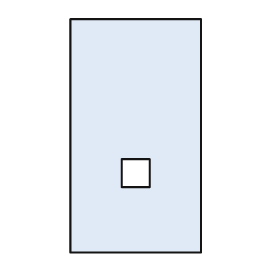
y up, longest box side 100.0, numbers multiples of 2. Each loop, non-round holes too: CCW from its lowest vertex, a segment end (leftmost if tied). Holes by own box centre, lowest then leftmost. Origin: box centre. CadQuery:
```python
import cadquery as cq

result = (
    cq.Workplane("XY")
    .moveTo(-28.0, -50.0)
    .lineTo(28.0, -50.0)
    .lineTo(28.0, 50.0)
    .lineTo(-28.0, 50.0)
    .close()
    .moveTo(-6.0, -22.0)
    .lineTo(6.0, -22.0)
    .lineTo(6.0, -10.0)
    .lineTo(-6.0, -10.0)
    .close()
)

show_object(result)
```